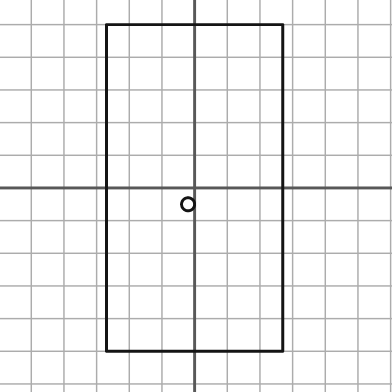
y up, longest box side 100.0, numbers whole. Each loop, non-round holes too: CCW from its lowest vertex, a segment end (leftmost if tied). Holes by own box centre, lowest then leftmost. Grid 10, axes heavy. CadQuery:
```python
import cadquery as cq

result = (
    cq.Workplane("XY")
    .moveTo(-27.0, -50.0)
    .lineTo(27.0, -50.0)
    .lineTo(27.0, 50.0)
    .lineTo(-27.0, 50.0)
    .close()
    .moveTo(-2.0, -5.0)
    .circle(2.0)
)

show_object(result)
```